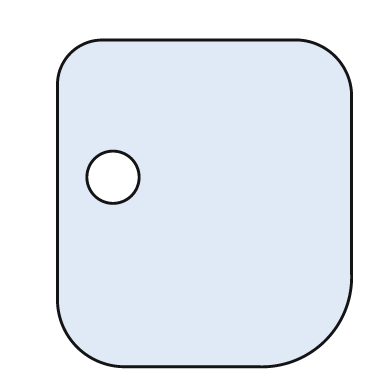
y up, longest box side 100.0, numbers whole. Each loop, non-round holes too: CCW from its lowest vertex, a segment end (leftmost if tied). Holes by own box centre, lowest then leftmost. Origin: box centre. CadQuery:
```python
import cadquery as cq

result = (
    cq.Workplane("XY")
    .moveTo(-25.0, -50.0)
    .lineTo(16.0, -50.0)
    .threePointArc((37.0, -42.0), (45.0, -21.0))
    .lineTo(45.0, 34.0)
    .threePointArc((40.0, 45.0), (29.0, 50.0))
    .lineTo(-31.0, 50.0)
    .threePointArc((-41.0, 46.0), (-45.0, 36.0))
    .lineTo(-45.0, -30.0)
    .threePointArc((-39.0, -44.0), (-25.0, -50.0))
    .close()
    .moveTo(-28.0, 8.0)
    .circle(8.0)
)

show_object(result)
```